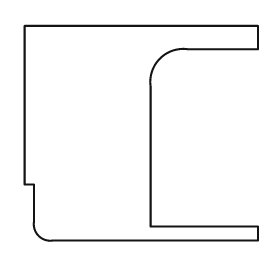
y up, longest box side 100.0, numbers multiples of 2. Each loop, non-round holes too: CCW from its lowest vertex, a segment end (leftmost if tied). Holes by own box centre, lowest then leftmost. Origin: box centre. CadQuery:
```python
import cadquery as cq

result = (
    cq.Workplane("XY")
    .moveTo(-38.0, -46.0)
    .lineTo(50.0, -46.0)
    .lineTo(50.0, -40.0)
    .lineTo(4.0, -40.0)
    .lineTo(4.0, 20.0)
    .threePointArc((8.0, 32.0), (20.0, 36.0))
    .lineTo(50.0, 36.0)
    .lineTo(50.0, 46.0)
    .lineTo(-50.0, 46.0)
    .lineTo(-50.0, -22.0)
    .lineTo(-46.0, -22.0)
    .lineTo(-46.0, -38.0)
    .threePointArc((-44.0, -44.0), (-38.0, -46.0))
    .close()
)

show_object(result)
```